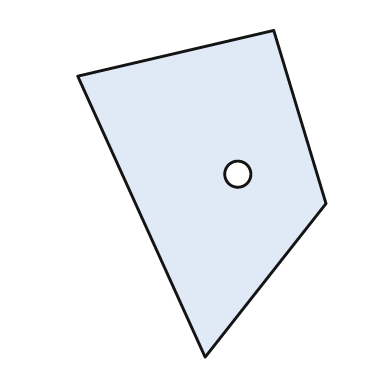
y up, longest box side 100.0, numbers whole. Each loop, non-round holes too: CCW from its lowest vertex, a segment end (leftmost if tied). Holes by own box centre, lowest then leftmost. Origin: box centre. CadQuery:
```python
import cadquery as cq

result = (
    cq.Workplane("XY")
    .moveTo(1.0, -50.0)
    .lineTo(38.0, -3.0)
    .lineTo(22.0, 50.0)
    .lineTo(-38.0, 36.0)
    .close()
    .moveTo(11.0, 6.0)
    .circle(4.0)
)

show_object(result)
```